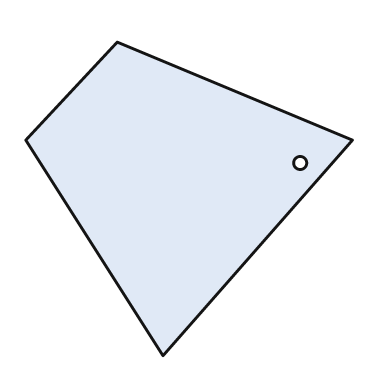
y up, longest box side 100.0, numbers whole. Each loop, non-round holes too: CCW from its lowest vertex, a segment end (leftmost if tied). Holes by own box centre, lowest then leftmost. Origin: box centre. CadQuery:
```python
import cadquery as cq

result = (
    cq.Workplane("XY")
    .moveTo(-8.0, -48.0)
    .lineTo(50.0, 18.0)
    .lineTo(-22.0, 48.0)
    .lineTo(-50.0, 18.0)
    .close()
    .moveTo(34.0, 11.0)
    .circle(2.0)
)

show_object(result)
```